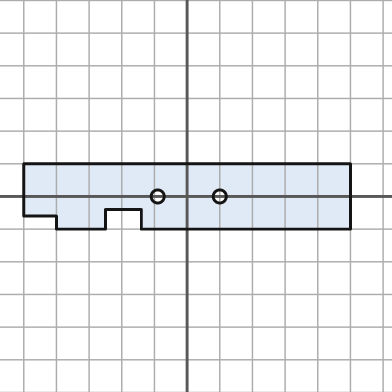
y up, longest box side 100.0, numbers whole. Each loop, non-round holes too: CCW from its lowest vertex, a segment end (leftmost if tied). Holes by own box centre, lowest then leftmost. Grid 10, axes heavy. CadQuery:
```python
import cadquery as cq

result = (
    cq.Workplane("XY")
    .moveTo(-40.0, -10.0)
    .lineTo(-25.0, -10.0)
    .lineTo(-25.0, -4.0)
    .lineTo(-14.0, -4.0)
    .lineTo(-14.0, -10.0)
    .lineTo(50.0, -10.0)
    .lineTo(50.0, 10.0)
    .lineTo(-50.0, 10.0)
    .lineTo(-50.0, -6.0)
    .lineTo(-40.0, -6.0)
    .close()
    .moveTo(-9.0, 0.0)
    .circle(2.0)
    .moveTo(10.0, 0.0)
    .circle(2.0)
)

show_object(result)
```